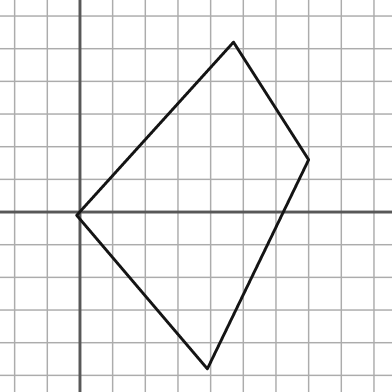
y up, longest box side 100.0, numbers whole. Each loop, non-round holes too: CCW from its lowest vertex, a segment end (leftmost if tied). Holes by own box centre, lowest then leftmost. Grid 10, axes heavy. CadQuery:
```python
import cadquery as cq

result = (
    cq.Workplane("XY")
    .moveTo(39.0, -48.0)
    .lineTo(70.0, 16.0)
    .lineTo(47.0, 52.0)
    .lineTo(-1.0, -1.0)
    .close()
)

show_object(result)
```